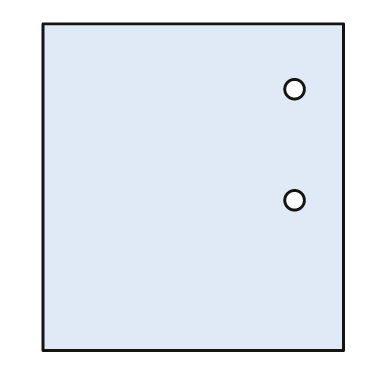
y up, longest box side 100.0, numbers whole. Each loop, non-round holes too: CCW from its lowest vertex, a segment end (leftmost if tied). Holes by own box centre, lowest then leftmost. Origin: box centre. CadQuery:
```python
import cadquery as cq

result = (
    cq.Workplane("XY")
    .moveTo(-46.0, -50.0)
    .lineTo(46.0, -50.0)
    .lineTo(46.0, 50.0)
    .lineTo(-46.0, 50.0)
    .close()
    .moveTo(31.0, -4.0)
    .circle(3.0)
    .moveTo(31.0, 30.0)
    .circle(3.0)
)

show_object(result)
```